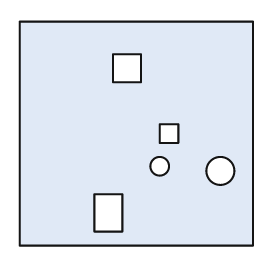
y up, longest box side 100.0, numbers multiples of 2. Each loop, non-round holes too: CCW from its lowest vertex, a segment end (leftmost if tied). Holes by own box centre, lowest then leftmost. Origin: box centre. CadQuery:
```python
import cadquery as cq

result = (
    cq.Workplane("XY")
    .moveTo(-50.0, -48.0)
    .lineTo(50.0, -48.0)
    .lineTo(50.0, 48.0)
    .lineTo(-50.0, 48.0)
    .close()
    .moveTo(-18.0, -42.0)
    .lineTo(-6.0, -42.0)
    .lineTo(-6.0, -26.0)
    .lineTo(-18.0, -26.0)
    .close()
    .moveTo(36.0, -16.0)
    .circle(6.0)
    .moveTo(10.0, -14.0)
    .circle(4.0)
    .moveTo(10.0, -4.0)
    .lineTo(18.0, -4.0)
    .lineTo(18.0, 4.0)
    .lineTo(10.0, 4.0)
    .close()
    .moveTo(-10.0, 22.0)
    .lineTo(2.0, 22.0)
    .lineTo(2.0, 34.0)
    .lineTo(-10.0, 34.0)
    .close()
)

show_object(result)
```